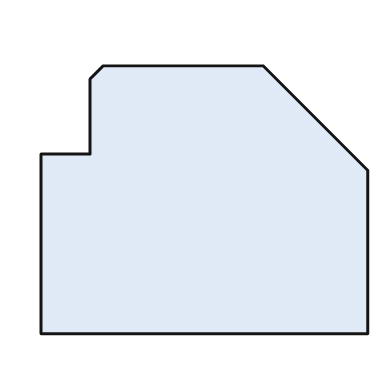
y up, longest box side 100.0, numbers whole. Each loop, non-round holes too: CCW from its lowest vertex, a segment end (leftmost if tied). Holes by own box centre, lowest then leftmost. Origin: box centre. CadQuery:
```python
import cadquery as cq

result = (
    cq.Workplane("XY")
    .moveTo(-50.0, -41.0)
    .lineTo(50.0, -41.0)
    .lineTo(50.0, 9.0)
    .lineTo(18.0, 41.0)
    .lineTo(-31.0, 41.0)
    .lineTo(-35.0, 37.0)
    .lineTo(-35.0, 14.0)
    .lineTo(-50.0, 14.0)
    .close()
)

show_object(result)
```